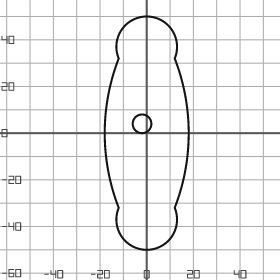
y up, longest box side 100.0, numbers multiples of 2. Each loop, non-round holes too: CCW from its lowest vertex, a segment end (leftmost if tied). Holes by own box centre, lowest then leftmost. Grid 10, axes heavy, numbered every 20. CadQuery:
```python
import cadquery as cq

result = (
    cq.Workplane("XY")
    .moveTo(-12.0, -32.0)
    .threePointArc((0.0, -50.0), (12.0, -32.0))
    .threePointArc((18.0, 0.0), (12.0, 32.0))
    .threePointArc((0.0, 50.0), (-12.0, 32.0))
    .threePointArc((-18.0, 0.0), (-12.0, -32.0))
    .close()
    .moveTo(-2.0, 4.0)
    .circle(4.0)
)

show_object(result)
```